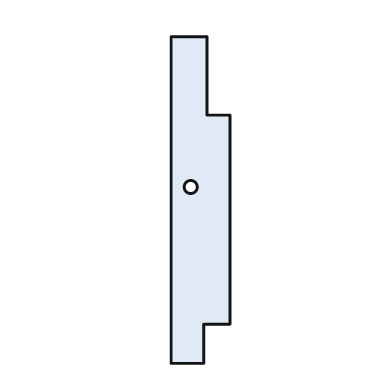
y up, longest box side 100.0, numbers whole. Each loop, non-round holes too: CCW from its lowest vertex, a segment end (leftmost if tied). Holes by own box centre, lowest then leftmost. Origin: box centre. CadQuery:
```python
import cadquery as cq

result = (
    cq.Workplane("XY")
    .moveTo(-9.0, -50.0)
    .lineTo(1.0, -50.0)
    .lineTo(1.0, -38.0)
    .lineTo(9.0, -38.0)
    .lineTo(9.0, 26.0)
    .lineTo(2.0, 26.0)
    .lineTo(2.0, 50.0)
    .lineTo(-9.0, 50.0)
    .close()
    .moveTo(-3.0, 4.0)
    .circle(2.0)
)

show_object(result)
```